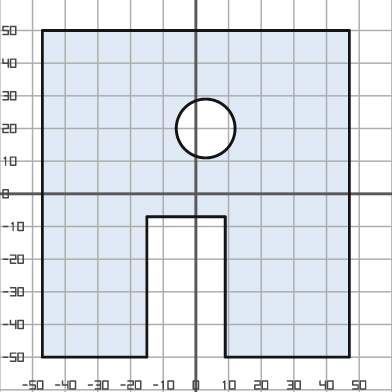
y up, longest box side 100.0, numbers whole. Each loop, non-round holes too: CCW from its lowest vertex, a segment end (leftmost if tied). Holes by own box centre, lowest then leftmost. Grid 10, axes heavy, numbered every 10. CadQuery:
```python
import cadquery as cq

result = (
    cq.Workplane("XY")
    .moveTo(-47.0, -50.0)
    .lineTo(-15.0, -50.0)
    .lineTo(-15.0, -7.0)
    .lineTo(9.0, -7.0)
    .lineTo(9.0, -50.0)
    .lineTo(47.0, -50.0)
    .lineTo(47.0, 50.0)
    .lineTo(-47.0, 50.0)
    .close()
    .moveTo(3.0, 20.0)
    .circle(9.0)
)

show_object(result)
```